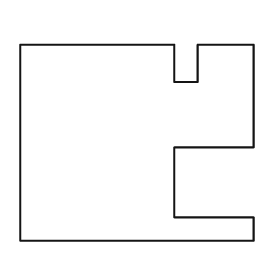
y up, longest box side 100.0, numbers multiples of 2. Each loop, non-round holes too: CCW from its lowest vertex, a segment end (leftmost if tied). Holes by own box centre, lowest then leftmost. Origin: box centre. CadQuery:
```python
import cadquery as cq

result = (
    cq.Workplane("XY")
    .moveTo(-50.0, -42.0)
    .lineTo(50.0, -42.0)
    .lineTo(50.0, -32.0)
    .lineTo(16.0, -32.0)
    .lineTo(16.0, -2.0)
    .lineTo(50.0, -2.0)
    .lineTo(50.0, 42.0)
    .lineTo(26.0, 42.0)
    .lineTo(26.0, 26.0)
    .lineTo(16.0, 26.0)
    .lineTo(16.0, 42.0)
    .lineTo(-50.0, 42.0)
    .close()
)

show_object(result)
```